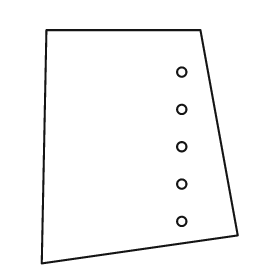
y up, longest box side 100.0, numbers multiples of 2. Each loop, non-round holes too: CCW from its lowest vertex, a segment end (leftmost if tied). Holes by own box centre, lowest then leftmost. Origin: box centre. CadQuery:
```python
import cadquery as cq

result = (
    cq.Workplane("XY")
    .moveTo(-42.0, -50.0)
    .lineTo(42.0, -38.0)
    .lineTo(26.0, 50.0)
    .lineTo(-40.0, 50.0)
    .close()
    .moveTo(18.0, -32.0)
    .circle(2.0)
    .moveTo(18.0, -16.0)
    .circle(2.0)
    .moveTo(18.0, 0.0)
    .circle(2.0)
    .moveTo(18.0, 16.0)
    .circle(2.0)
    .moveTo(18.0, 32.0)
    .circle(2.0)
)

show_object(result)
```